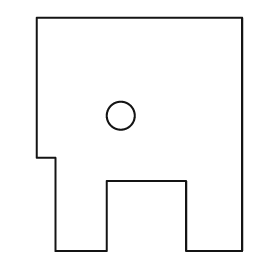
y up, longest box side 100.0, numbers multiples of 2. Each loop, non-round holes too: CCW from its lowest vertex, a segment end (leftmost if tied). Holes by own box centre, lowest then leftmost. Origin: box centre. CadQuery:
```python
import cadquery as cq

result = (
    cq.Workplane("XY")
    .moveTo(-36.0, -50.0)
    .lineTo(-14.0, -50.0)
    .lineTo(-14.0, -20.0)
    .lineTo(20.0, -20.0)
    .lineTo(20.0, -50.0)
    .lineTo(44.0, -50.0)
    .lineTo(44.0, 50.0)
    .lineTo(-44.0, 50.0)
    .lineTo(-44.0, -10.0)
    .lineTo(-36.0, -10.0)
    .close()
    .moveTo(-8.0, 8.0)
    .circle(6.0)
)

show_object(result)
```